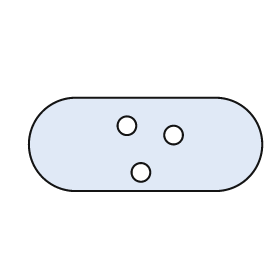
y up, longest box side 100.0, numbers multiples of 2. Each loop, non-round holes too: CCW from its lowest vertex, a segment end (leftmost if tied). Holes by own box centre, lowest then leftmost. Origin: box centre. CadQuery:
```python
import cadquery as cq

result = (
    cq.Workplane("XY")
    .moveTo(-30.0, -20.0)
    .lineTo(30.0, -20.0)
    .threePointArc((50.0, 0.0), (30.0, 20.0))
    .lineTo(-30.0, 20.0)
    .threePointArc((-50.0, 0.0), (-30.0, -20.0))
    .close()
    .moveTo(-2.0, -12.0)
    .circle(4.0)
    .moveTo(12.0, 4.0)
    .circle(4.0)
    .moveTo(-8.0, 8.0)
    .circle(4.0)
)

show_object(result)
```